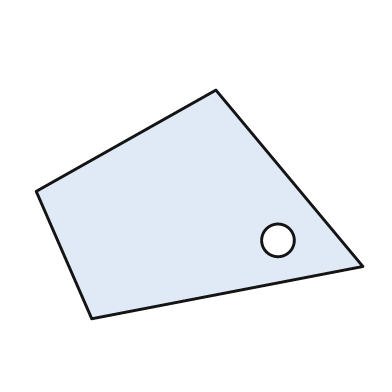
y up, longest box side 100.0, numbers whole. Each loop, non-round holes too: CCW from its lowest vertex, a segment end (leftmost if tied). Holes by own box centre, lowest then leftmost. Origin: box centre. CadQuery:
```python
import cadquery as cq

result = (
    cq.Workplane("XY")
    .moveTo(-33.0, -35.0)
    .lineTo(50.0, -19.0)
    .lineTo(5.0, 35.0)
    .lineTo(-50.0, 4.0)
    .close()
    .moveTo(24.0, -11.0)
    .circle(5.0)
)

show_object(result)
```